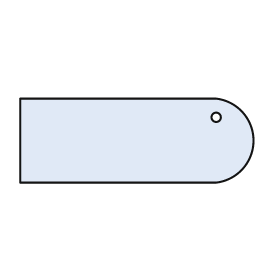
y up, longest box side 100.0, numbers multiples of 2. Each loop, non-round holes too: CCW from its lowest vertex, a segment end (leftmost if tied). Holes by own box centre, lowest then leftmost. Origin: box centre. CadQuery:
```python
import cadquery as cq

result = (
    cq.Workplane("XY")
    .moveTo(-50.0, -18.0)
    .lineTo(34.0, -18.0)
    .threePointArc((50.0, 0.0), (34.0, 18.0))
    .lineTo(-50.0, 18.0)
    .close()
    .moveTo(34.0, 10.0)
    .circle(2.0)
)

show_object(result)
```